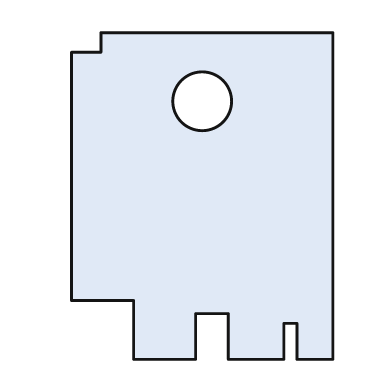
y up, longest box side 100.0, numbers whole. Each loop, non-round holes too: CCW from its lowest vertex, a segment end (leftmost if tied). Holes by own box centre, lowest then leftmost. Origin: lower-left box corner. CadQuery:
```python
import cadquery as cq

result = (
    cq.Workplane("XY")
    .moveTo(19.0, 0.0)
    .lineTo(38.0, 0.0)
    .lineTo(38.0, 14.0)
    .lineTo(48.0, 14.0)
    .lineTo(48.0, 0.0)
    .lineTo(65.0, 0.0)
    .lineTo(65.0, 11.0)
    .lineTo(69.0, 11.0)
    .lineTo(69.0, 0.0)
    .lineTo(80.0, 0.0)
    .lineTo(80.0, 100.0)
    .lineTo(9.0, 100.0)
    .lineTo(9.0, 94.0)
    .lineTo(0.0, 94.0)
    .lineTo(0.0, 18.0)
    .lineTo(19.0, 18.0)
    .close()
    .moveTo(40.0, 79.0)
    .circle(9.0)
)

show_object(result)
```